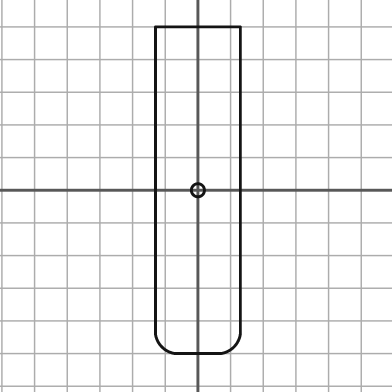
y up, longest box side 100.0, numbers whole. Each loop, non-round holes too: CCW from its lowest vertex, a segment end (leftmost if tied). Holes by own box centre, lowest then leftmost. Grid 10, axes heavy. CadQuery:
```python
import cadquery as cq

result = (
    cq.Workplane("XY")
    .moveTo(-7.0, -50.0)
    .lineTo(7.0, -50.0)
    .threePointArc((11.0, -48.0), (13.0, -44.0))
    .lineTo(13.0, 50.0)
    .lineTo(-13.0, 50.0)
    .lineTo(-13.0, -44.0)
    .threePointArc((-11.0, -48.0), (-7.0, -50.0))
    .close()
    .moveTo(0.0, 0.0)
    .circle(2.0)
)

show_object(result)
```